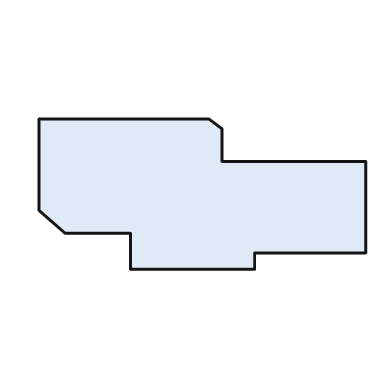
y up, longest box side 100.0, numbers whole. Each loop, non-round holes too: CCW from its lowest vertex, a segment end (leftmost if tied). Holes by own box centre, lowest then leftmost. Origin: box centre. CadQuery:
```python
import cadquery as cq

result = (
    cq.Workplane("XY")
    .moveTo(-22.0, -23.0)
    .lineTo(16.0, -23.0)
    .lineTo(16.0, -18.0)
    .lineTo(50.0, -18.0)
    .lineTo(50.0, 10.0)
    .lineTo(6.0, 10.0)
    .lineTo(6.0, 20.0)
    .lineTo(2.0, 23.0)
    .lineTo(-50.0, 23.0)
    .lineTo(-50.0, -5.0)
    .lineTo(-42.0, -12.0)
    .lineTo(-22.0, -12.0)
    .close()
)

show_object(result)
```